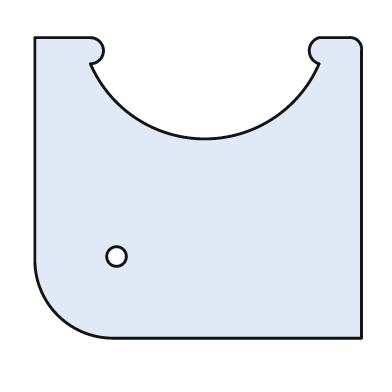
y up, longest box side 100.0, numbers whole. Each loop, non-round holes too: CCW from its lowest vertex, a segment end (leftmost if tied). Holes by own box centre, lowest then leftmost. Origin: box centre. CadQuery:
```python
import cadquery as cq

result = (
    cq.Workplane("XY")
    .moveTo(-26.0, -46.0)
    .lineTo(50.0, -46.0)
    .lineTo(50.0, 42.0)
    .threePointArc((49.0, 45.0), (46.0, 46.0))
    .lineTo(37.0, 46.0)
    .threePointArc((34.0, 42.0), (37.0, 38.0))
    .threePointArc((2.0, 15.0), (-33.0, 38.0))
    .threePointArc((-29.0, 42.0), (-33.0, 46.0))
    .lineTo(-50.0, 46.0)
    .lineTo(-50.0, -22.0)
    .threePointArc((-43.0, -39.0), (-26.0, -46.0))
    .close()
    .moveTo(-25.0, -21.0)
    .circle(3.0)
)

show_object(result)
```